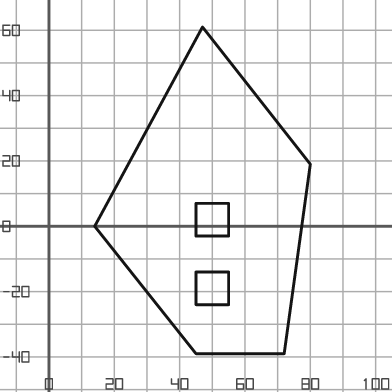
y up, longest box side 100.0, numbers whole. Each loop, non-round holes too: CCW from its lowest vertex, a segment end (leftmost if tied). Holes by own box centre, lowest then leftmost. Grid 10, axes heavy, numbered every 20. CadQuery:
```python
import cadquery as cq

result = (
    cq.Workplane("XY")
    .moveTo(45.0, -39.0)
    .lineTo(72.0, -39.0)
    .lineTo(80.0, 19.0)
    .lineTo(47.0, 61.0)
    .lineTo(14.0, 0.0)
    .close()
    .moveTo(45.0, -24.0)
    .lineTo(55.0, -24.0)
    .lineTo(55.0, -14.0)
    .lineTo(45.0, -14.0)
    .close()
    .moveTo(45.0, -3.0)
    .lineTo(55.0, -3.0)
    .lineTo(55.0, 7.0)
    .lineTo(45.0, 7.0)
    .close()
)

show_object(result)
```